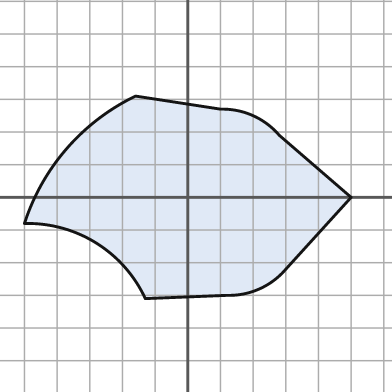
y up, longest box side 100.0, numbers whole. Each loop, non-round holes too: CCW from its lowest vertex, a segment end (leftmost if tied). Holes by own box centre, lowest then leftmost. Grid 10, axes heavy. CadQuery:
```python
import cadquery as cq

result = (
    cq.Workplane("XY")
    .moveTo(-13.0, -31.0)
    .lineTo(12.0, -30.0)
    .threePointArc((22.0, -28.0), (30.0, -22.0))
    .lineTo(50.0, 0.0)
    .lineTo(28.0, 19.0)
    .threePointArc((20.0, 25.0), (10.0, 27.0))
    .lineTo(-16.0, 31.0)
    .threePointArc((-37.0, 15.0), (-50.0, -8.0))
    .threePointArc((-28.0, -14.0), (-13.0, -31.0))
    .close()
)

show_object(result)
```